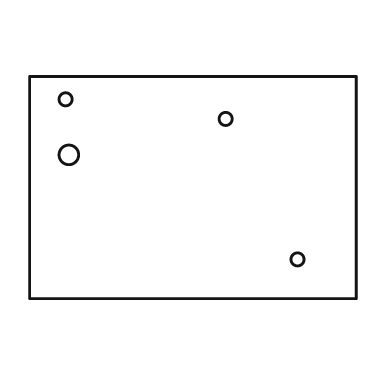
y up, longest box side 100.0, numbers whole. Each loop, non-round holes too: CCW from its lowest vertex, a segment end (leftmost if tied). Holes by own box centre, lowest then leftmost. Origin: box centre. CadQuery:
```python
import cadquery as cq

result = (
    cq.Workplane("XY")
    .moveTo(-50.0, -34.0)
    .lineTo(50.0, -34.0)
    .lineTo(50.0, 34.0)
    .lineTo(-50.0, 34.0)
    .close()
    .moveTo(32.0, -22.0)
    .circle(2.0)
    .moveTo(-38.0, 10.0)
    .circle(3.0)
    .moveTo(10.0, 21.0)
    .circle(2.0)
    .moveTo(-39.0, 27.0)
    .circle(2.0)
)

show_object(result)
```